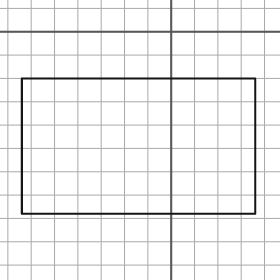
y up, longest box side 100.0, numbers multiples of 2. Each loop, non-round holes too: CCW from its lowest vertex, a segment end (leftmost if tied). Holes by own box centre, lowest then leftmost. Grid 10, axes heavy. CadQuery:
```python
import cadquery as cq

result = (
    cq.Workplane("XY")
    .moveTo(-64.0, -78.0)
    .lineTo(36.0, -78.0)
    .lineTo(36.0, -20.0)
    .lineTo(-64.0, -20.0)
    .close()
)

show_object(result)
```